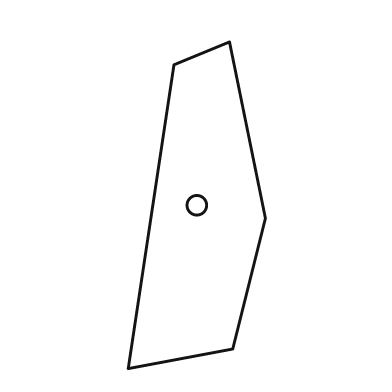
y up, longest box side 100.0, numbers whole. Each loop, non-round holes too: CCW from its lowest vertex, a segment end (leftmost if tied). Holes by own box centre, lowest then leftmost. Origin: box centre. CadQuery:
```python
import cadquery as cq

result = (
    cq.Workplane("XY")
    .moveTo(-21.0, -50.0)
    .lineTo(11.0, -44.0)
    .lineTo(21.0, -4.0)
    .lineTo(10.0, 50.0)
    .lineTo(-7.0, 43.0)
    .close()
    .moveTo(0.0, 0.0)
    .circle(3.0)
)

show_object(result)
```